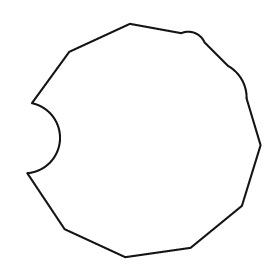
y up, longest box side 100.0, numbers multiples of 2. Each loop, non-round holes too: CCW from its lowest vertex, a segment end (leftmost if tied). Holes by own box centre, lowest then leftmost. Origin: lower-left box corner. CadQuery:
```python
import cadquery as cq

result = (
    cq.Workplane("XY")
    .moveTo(42.0, 0.0)
    .lineTo(70.0, 4.0)
    .lineTo(92.0, 22.0)
    .lineTo(100.0, 48.0)
    .lineTo(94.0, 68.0)
    .threePointArc((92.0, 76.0), (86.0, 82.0))
    .lineTo(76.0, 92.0)
    .threePointArc((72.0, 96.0), (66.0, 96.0))
    .lineTo(44.0, 100.0)
    .lineTo(18.0, 88.0)
    .lineTo(2.0, 66.0)
    .threePointArc((14.0, 50.0), (0.0, 36.0))
    .lineTo(16.0, 12.0)
    .close()
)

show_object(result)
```